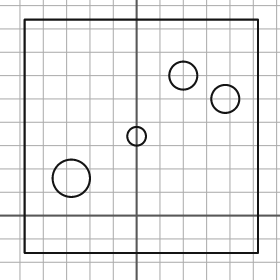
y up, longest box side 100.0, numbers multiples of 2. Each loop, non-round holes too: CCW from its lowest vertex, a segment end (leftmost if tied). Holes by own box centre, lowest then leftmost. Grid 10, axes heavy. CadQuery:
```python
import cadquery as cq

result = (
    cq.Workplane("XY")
    .moveTo(-48.0, -16.0)
    .lineTo(52.0, -16.0)
    .lineTo(52.0, 84.0)
    .lineTo(-48.0, 84.0)
    .close()
    .moveTo(-28.0, 16.0)
    .circle(8.0)
    .moveTo(0.0, 34.0)
    .circle(4.0)
    .moveTo(38.0, 50.0)
    .circle(6.0)
    .moveTo(20.0, 60.0)
    .circle(6.0)
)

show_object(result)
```